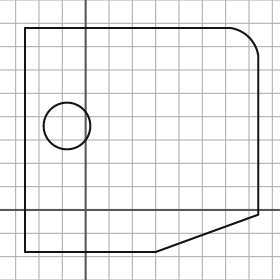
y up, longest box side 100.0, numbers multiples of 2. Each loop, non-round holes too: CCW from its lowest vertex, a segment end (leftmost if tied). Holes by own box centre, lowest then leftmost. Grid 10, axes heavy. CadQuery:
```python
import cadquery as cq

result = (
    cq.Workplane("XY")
    .moveTo(-26.0, -18.0)
    .lineTo(30.0, -18.0)
    .lineTo(74.0, -2.0)
    .lineTo(74.0, 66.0)
    .threePointArc((70.0, 74.0), (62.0, 78.0))
    .lineTo(-26.0, 78.0)
    .close()
    .moveTo(-8.0, 36.0)
    .circle(10.0)
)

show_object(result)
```